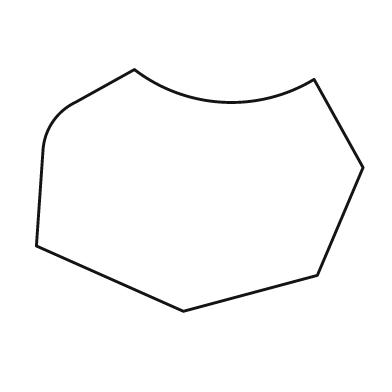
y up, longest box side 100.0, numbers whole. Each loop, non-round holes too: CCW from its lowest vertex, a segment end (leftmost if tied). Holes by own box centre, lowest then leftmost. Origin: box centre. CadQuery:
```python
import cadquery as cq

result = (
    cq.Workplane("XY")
    .moveTo(-5.0, -37.0)
    .lineTo(36.0, -26.0)
    .lineTo(50.0, 7.0)
    .lineTo(35.0, 34.0)
    .threePointArc((7.0, 27.0), (-20.0, 37.0))
    .lineTo(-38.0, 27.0)
    .threePointArc((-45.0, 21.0), (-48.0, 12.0))
    .lineTo(-50.0, -17.0)
    .close()
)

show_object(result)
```